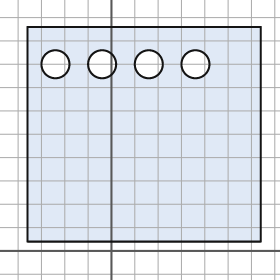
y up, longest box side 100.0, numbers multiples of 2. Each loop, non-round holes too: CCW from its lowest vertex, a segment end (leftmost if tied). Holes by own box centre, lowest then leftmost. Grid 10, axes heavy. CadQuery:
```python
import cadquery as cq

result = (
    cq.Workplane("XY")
    .moveTo(-36.0, 4.0)
    .lineTo(64.0, 4.0)
    .lineTo(64.0, 96.0)
    .lineTo(-36.0, 96.0)
    .close()
    .moveTo(-24.0, 80.0)
    .circle(6.0)
    .moveTo(-4.0, 80.0)
    .circle(6.0)
    .moveTo(16.0, 80.0)
    .circle(6.0)
    .moveTo(36.0, 80.0)
    .circle(6.0)
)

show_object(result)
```